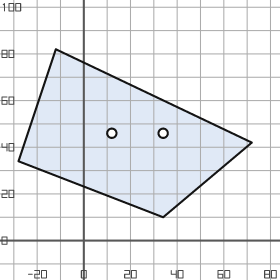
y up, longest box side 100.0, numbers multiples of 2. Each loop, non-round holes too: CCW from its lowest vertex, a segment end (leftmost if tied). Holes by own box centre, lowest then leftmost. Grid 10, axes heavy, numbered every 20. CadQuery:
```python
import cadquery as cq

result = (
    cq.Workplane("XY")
    .moveTo(34.0, 10.0)
    .lineTo(72.0, 42.0)
    .lineTo(-12.0, 82.0)
    .lineTo(-28.0, 34.0)
    .close()
    .moveTo(12.0, 46.0)
    .circle(2.0)
    .moveTo(34.0, 46.0)
    .circle(2.0)
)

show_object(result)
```